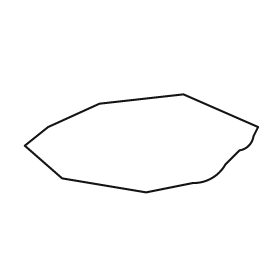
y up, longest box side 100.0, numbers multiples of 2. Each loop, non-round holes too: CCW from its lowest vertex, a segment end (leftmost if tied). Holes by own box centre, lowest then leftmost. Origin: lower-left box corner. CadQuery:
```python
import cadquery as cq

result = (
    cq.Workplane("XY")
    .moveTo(52.0, 0.0)
    .lineTo(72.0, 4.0)
    .threePointArc((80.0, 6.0), (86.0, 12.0))
    .lineTo(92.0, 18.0)
    .threePointArc((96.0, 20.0), (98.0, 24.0))
    .lineTo(100.0, 28.0)
    .lineTo(68.0, 42.0)
    .lineTo(32.0, 38.0)
    .lineTo(10.0, 28.0)
    .lineTo(0.0, 20.0)
    .lineTo(16.0, 6.0)
    .close()
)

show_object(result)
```